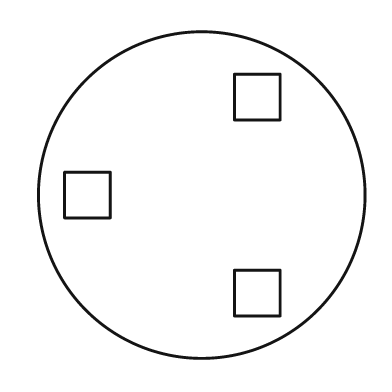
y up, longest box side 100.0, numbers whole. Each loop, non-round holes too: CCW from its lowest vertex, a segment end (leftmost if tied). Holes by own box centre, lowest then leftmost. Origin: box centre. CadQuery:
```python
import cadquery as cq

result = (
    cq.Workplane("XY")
    .moveTo(0.0, 0.0)
    .circle(50.0)
    .moveTo(10.0, -37.0)
    .lineTo(24.0, -37.0)
    .lineTo(24.0, -23.0)
    .lineTo(10.0, -23.0)
    .close()
    .moveTo(-42.0, -7.0)
    .lineTo(-28.0, -7.0)
    .lineTo(-28.0, 7.0)
    .lineTo(-42.0, 7.0)
    .close()
    .moveTo(10.0, 23.0)
    .lineTo(24.0, 23.0)
    .lineTo(24.0, 37.0)
    .lineTo(10.0, 37.0)
    .close()
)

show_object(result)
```